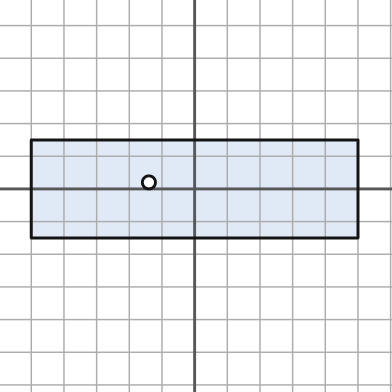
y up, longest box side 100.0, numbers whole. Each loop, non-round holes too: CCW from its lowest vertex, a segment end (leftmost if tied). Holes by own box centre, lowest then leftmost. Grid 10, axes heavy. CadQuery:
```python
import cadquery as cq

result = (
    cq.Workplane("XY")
    .moveTo(-50.0, -15.0)
    .lineTo(50.0, -15.0)
    .lineTo(50.0, 15.0)
    .lineTo(-50.0, 15.0)
    .close()
    .moveTo(-14.0, 2.0)
    .circle(2.0)
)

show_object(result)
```